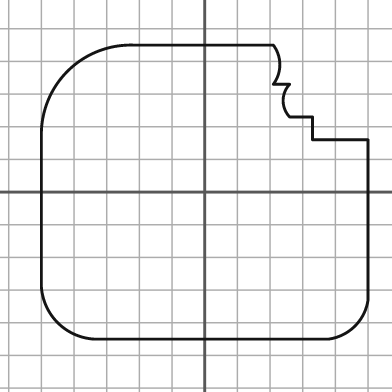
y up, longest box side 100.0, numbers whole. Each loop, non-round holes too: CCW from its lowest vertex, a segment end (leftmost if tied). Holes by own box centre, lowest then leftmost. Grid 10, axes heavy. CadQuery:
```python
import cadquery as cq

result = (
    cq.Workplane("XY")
    .moveTo(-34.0, -45.0)
    .lineTo(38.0, -45.0)
    .threePointArc((46.0, -41.0), (50.0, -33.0))
    .lineTo(50.0, 16.0)
    .lineTo(33.0, 16.0)
    .lineTo(33.0, 23.0)
    .lineTo(26.0, 23.0)
    .threePointArc((24.0, 28.0), (26.0, 33.0))
    .lineTo(21.0, 33.0)
    .threePointArc((23.0, 39.0), (21.0, 45.0))
    .lineTo(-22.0, 45.0)
    .threePointArc((-42.0, 37.0), (-50.0, 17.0))
    .lineTo(-50.0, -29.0)
    .threePointArc((-45.0, -40.0), (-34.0, -45.0))
    .close()
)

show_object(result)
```